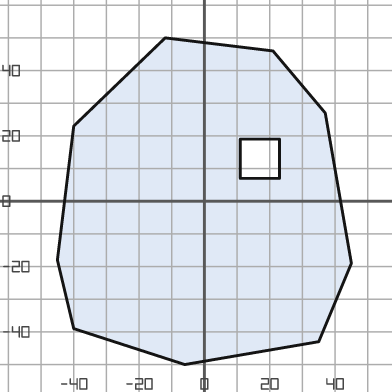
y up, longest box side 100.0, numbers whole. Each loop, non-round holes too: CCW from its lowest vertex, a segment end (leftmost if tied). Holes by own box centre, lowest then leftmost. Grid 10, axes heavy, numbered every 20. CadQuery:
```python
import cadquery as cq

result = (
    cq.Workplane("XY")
    .moveTo(-6.0, -50.0)
    .lineTo(35.0, -43.0)
    .lineTo(45.0, -19.0)
    .lineTo(37.0, 27.0)
    .lineTo(21.0, 46.0)
    .lineTo(-12.0, 50.0)
    .lineTo(-40.0, 23.0)
    .lineTo(-45.0, -18.0)
    .lineTo(-40.0, -39.0)
    .close()
    .moveTo(11.0, 7.0)
    .lineTo(23.0, 7.0)
    .lineTo(23.0, 19.0)
    .lineTo(11.0, 19.0)
    .close()
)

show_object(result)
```